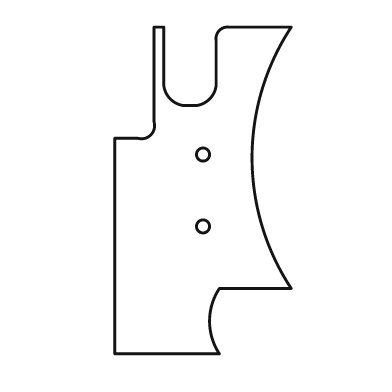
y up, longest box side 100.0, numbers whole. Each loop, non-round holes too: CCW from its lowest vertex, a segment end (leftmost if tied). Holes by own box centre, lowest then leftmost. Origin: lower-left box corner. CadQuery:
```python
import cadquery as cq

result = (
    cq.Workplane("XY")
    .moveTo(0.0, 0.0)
    .lineTo(32.0, 0.0)
    .threePointArc((29.0, 10.0), (32.0, 20.0))
    .lineTo(54.0, 20.0)
    .threePointArc((42.0, 60.0), (54.0, 100.0))
    .lineTo(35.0, 100.0)
    .threePointArc((32.0, 99.0), (31.0, 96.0))
    .lineTo(31.0, 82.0)
    .threePointArc((29.0, 78.0), (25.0, 76.0))
    .lineTo(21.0, 76.0)
    .threePointArc((17.0, 78.0), (15.0, 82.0))
    .lineTo(15.0, 100.0)
    .lineTo(12.0, 100.0)
    .lineTo(12.0, 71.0)
    .threePointArc((11.0, 67.0), (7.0, 66.0))
    .lineTo(0.0, 66.0)
    .close()
    .moveTo(27.0, 39.0)
    .circle(2.0)
    .moveTo(27.0, 61.0)
    .circle(2.0)
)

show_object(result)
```